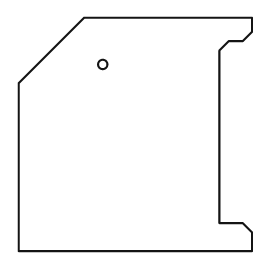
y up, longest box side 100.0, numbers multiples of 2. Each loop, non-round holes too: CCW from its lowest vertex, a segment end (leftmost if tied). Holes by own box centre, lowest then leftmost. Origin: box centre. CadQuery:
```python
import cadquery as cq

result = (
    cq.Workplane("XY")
    .moveTo(-50.0, -50.0)
    .lineTo(50.0, -50.0)
    .lineTo(50.0, -42.0)
    .lineTo(46.0, -38.0)
    .lineTo(36.0, -38.0)
    .lineTo(36.0, 36.0)
    .lineTo(40.0, 40.0)
    .lineTo(46.0, 40.0)
    .lineTo(50.0, 44.0)
    .lineTo(50.0, 50.0)
    .lineTo(-22.0, 50.0)
    .lineTo(-50.0, 22.0)
    .close()
    .moveTo(-14.0, 30.0)
    .circle(2.0)
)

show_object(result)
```